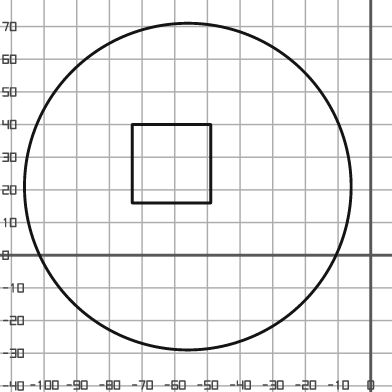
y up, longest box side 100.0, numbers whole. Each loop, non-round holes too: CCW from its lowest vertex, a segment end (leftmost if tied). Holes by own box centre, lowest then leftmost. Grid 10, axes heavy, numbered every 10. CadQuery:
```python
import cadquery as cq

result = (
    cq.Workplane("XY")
    .moveTo(-56.0, 21.0)
    .circle(50.0)
    .moveTo(-73.0, 16.0)
    .lineTo(-49.0, 16.0)
    .lineTo(-49.0, 40.0)
    .lineTo(-73.0, 40.0)
    .close()
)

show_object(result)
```